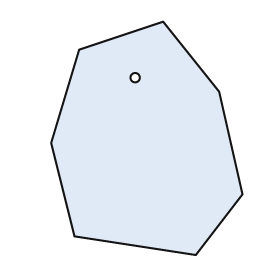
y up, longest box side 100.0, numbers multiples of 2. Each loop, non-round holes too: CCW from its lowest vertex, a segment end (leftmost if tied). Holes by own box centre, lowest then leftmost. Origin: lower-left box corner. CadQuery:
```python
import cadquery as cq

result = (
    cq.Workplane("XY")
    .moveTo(62.0, 0.0)
    .lineTo(82.0, 26.0)
    .lineTo(72.0, 70.0)
    .lineTo(48.0, 100.0)
    .lineTo(12.0, 88.0)
    .lineTo(0.0, 48.0)
    .lineTo(10.0, 8.0)
    .close()
    .moveTo(36.0, 76.0)
    .circle(2.0)
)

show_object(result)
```